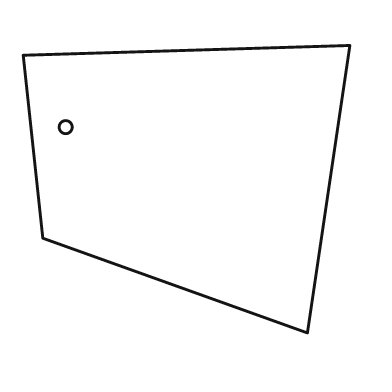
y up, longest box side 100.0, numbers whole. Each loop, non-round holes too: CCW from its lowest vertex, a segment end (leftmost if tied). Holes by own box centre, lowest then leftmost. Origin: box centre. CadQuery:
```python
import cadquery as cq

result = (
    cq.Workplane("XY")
    .moveTo(37.0, -44.0)
    .lineTo(50.0, 44.0)
    .lineTo(-50.0, 41.0)
    .lineTo(-44.0, -15.0)
    .close()
    .moveTo(-37.0, 19.0)
    .circle(2.0)
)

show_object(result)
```